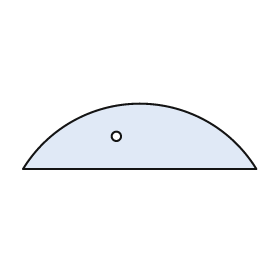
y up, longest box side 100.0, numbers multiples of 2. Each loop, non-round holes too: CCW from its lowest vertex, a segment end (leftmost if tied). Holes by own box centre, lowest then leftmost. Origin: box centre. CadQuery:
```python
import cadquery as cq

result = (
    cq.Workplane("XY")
    .moveTo(-50.0, -14.0)
    .lineTo(50.0, -14.0)
    .threePointArc((0.0, 14.0), (-50.0, -14.0))
    .close()
    .moveTo(-10.0, 0.0)
    .circle(2.0)
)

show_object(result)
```